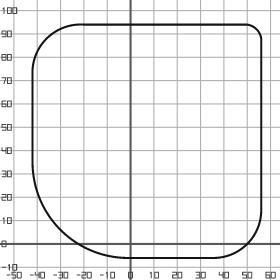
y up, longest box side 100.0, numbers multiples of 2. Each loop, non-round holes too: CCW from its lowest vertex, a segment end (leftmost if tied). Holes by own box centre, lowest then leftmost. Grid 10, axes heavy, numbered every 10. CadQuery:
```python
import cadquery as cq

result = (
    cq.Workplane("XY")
    .moveTo(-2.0, -6.0)
    .lineTo(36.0, -6.0)
    .threePointArc((50.0, 0.0), (56.0, 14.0))
    .lineTo(56.0, 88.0)
    .threePointArc((54.0, 92.0), (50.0, 94.0))
    .lineTo(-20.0, 94.0)
    .threePointArc((-36.0, 88.0), (-42.0, 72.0))
    .lineTo(-42.0, 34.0)
    .threePointArc((-30.0, 6.0), (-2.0, -6.0))
    .close()
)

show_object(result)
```